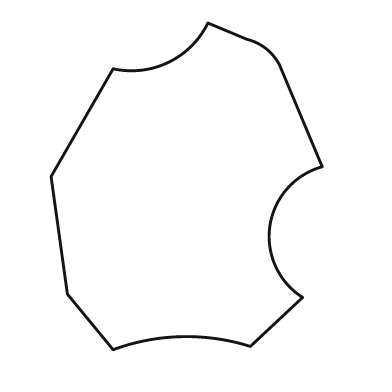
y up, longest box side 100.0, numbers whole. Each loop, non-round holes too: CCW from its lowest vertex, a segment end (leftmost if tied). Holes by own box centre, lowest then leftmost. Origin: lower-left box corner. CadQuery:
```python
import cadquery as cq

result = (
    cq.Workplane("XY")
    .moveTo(19.0, 0.0)
    .threePointArc((40.0, 4.0), (61.0, 1.0))
    .lineTo(77.0, 16.0)
    .threePointArc((67.0, 38.0), (83.0, 56.0))
    .lineTo(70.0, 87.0)
    .threePointArc((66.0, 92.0), (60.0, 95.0))
    .lineTo(48.0, 100.0)
    .threePointArc((36.0, 88.0), (19.0, 86.0))
    .lineTo(0.0, 53.0)
    .lineTo(5.0, 17.0)
    .close()
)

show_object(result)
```